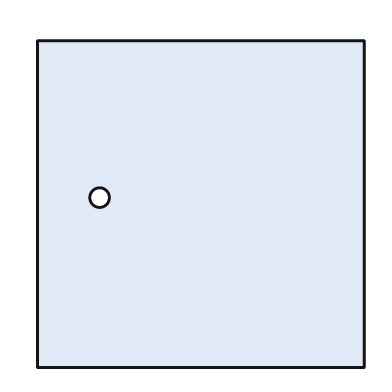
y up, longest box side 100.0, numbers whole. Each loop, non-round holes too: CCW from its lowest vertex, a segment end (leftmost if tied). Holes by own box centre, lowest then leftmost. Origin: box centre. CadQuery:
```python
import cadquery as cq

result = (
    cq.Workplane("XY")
    .moveTo(-50.0, -50.0)
    .lineTo(50.0, -50.0)
    .lineTo(50.0, 50.0)
    .lineTo(-50.0, 50.0)
    .close()
    .moveTo(-31.0, 2.0)
    .circle(3.0)
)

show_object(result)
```